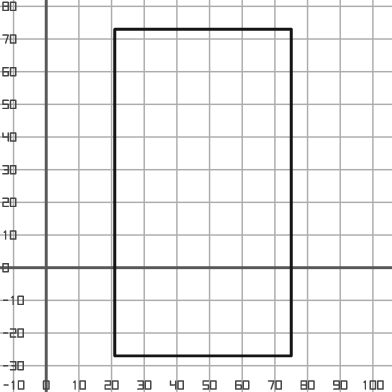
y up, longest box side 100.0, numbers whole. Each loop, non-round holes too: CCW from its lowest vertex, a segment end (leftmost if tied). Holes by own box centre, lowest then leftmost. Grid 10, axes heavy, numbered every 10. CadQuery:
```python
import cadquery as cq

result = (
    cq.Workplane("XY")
    .moveTo(21.0, -27.0)
    .lineTo(75.0, -27.0)
    .lineTo(75.0, 73.0)
    .lineTo(21.0, 73.0)
    .close()
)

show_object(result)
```